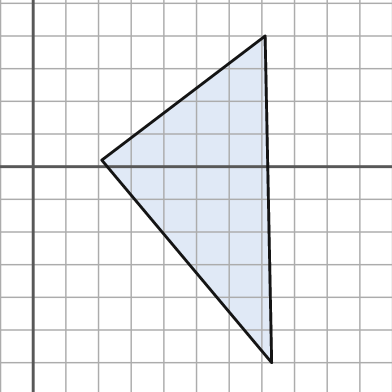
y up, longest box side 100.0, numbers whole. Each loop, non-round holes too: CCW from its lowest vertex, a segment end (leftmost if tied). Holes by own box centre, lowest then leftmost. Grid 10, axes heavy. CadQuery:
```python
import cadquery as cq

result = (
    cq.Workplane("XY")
    .moveTo(73.0, -60.0)
    .lineTo(71.0, 40.0)
    .lineTo(21.0, 2.0)
    .close()
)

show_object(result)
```